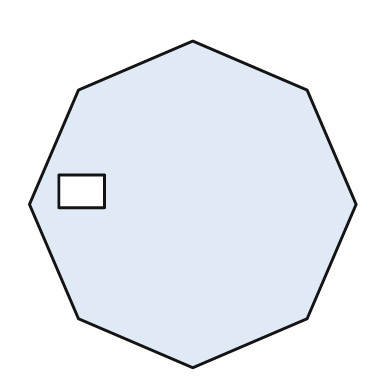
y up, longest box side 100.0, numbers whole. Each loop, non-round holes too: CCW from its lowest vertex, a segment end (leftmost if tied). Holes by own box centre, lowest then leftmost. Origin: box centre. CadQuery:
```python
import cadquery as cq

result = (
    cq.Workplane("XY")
    .moveTo(0.0, -50.0)
    .lineTo(35.0, -35.0)
    .lineTo(50.0, 0.0)
    .lineTo(35.0, 35.0)
    .lineTo(0.0, 50.0)
    .lineTo(-35.0, 35.0)
    .lineTo(-50.0, 0.0)
    .lineTo(-35.0, -35.0)
    .close()
    .moveTo(-41.0, -1.0)
    .lineTo(-27.0, -1.0)
    .lineTo(-27.0, 9.0)
    .lineTo(-41.0, 9.0)
    .close()
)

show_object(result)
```